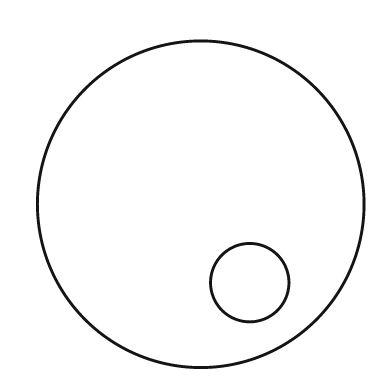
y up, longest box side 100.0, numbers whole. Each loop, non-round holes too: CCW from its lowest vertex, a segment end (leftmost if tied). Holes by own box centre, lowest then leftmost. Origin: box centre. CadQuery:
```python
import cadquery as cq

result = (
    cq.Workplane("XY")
    .moveTo(0.0, 0.0)
    .circle(50.0)
    .moveTo(15.0, -24.0)
    .circle(12.0)
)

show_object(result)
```